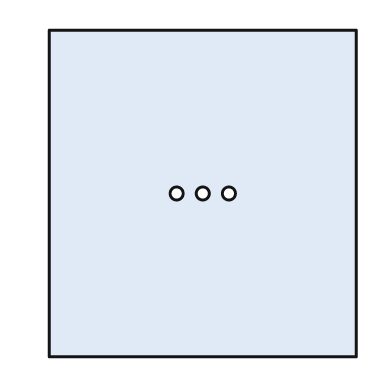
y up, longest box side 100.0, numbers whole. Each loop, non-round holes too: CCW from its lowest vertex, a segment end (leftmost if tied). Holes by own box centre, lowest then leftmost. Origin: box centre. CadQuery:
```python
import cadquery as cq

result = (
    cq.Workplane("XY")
    .moveTo(-47.0, -50.0)
    .lineTo(47.0, -50.0)
    .lineTo(47.0, 50.0)
    .lineTo(-47.0, 50.0)
    .close()
    .moveTo(-8.0, 0.0)
    .circle(2.0)
    .moveTo(0.0, 0.0)
    .circle(2.0)
    .moveTo(8.0, 0.0)
    .circle(2.0)
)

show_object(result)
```